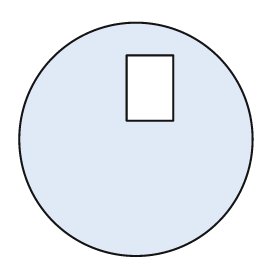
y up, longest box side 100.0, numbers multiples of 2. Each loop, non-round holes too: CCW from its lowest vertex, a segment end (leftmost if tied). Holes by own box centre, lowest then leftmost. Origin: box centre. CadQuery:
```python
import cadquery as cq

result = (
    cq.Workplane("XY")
    .moveTo(0.0, 0.0)
    .circle(50.0)
    .moveTo(-4.0, 8.0)
    .lineTo(16.0, 8.0)
    .lineTo(16.0, 36.0)
    .lineTo(-4.0, 36.0)
    .close()
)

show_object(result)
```